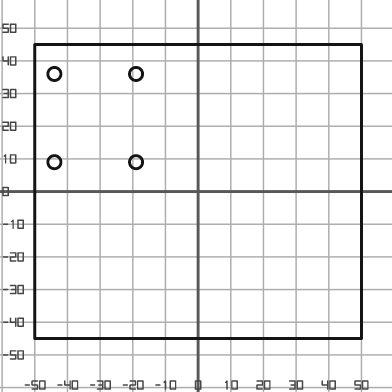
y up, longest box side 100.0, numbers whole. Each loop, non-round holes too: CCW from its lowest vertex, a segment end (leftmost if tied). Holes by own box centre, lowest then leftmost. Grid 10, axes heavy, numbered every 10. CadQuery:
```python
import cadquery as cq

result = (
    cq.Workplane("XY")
    .moveTo(-50.0, -45.0)
    .lineTo(50.0, -45.0)
    .lineTo(50.0, 45.0)
    .lineTo(-50.0, 45.0)
    .close()
    .moveTo(-44.0, 9.0)
    .circle(2.0)
    .moveTo(-19.0, 9.0)
    .circle(2.0)
    .moveTo(-44.0, 36.0)
    .circle(2.0)
    .moveTo(-19.0, 36.0)
    .circle(2.0)
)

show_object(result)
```